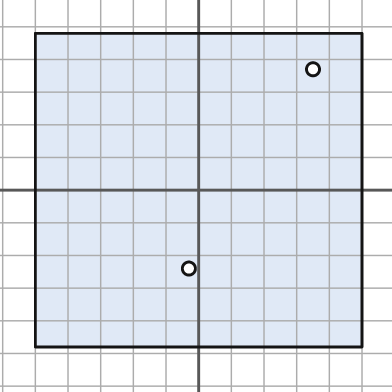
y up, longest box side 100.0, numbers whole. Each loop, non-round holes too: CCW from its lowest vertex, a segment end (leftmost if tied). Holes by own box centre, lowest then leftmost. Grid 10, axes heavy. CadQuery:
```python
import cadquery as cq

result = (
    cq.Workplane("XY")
    .moveTo(-50.0, -48.0)
    .lineTo(50.0, -48.0)
    .lineTo(50.0, 48.0)
    .lineTo(-50.0, 48.0)
    .close()
    .moveTo(-3.0, -24.0)
    .circle(2.0)
    .moveTo(35.0, 37.0)
    .circle(2.0)
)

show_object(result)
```